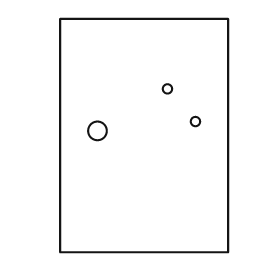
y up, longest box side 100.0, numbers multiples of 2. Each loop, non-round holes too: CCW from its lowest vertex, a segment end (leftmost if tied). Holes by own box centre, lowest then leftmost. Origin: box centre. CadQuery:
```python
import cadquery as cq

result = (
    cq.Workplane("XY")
    .moveTo(-36.0, -50.0)
    .lineTo(36.0, -50.0)
    .lineTo(36.0, 50.0)
    .lineTo(-36.0, 50.0)
    .close()
    .moveTo(-20.0, 2.0)
    .circle(4.0)
    .moveTo(22.0, 6.0)
    .circle(2.0)
    .moveTo(10.0, 20.0)
    .circle(2.0)
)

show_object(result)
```